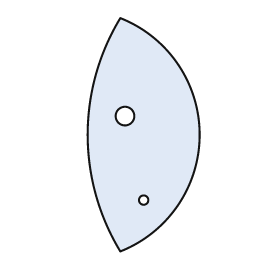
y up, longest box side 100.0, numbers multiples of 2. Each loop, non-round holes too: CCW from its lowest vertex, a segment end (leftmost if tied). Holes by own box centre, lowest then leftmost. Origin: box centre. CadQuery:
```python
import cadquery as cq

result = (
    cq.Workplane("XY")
    .moveTo(-10.0, -50.0)
    .threePointArc((24.0, 0.0), (-10.0, 50.0))
    .threePointArc((-24.0, 0.0), (-10.0, -50.0))
    .close()
    .moveTo(0.0, -28.0)
    .circle(2.0)
    .moveTo(-8.0, 8.0)
    .circle(4.0)
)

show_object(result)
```